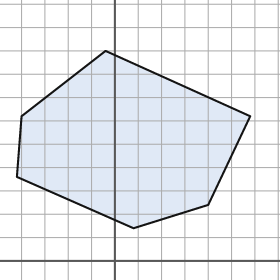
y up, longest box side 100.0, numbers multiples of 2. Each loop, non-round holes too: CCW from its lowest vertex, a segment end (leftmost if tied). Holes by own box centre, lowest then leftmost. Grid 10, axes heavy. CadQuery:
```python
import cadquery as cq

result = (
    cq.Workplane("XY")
    .moveTo(8.0, 14.0)
    .lineTo(40.0, 24.0)
    .lineTo(58.0, 62.0)
    .lineTo(-4.0, 90.0)
    .lineTo(-40.0, 62.0)
    .lineTo(-42.0, 36.0)
    .close()
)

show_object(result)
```